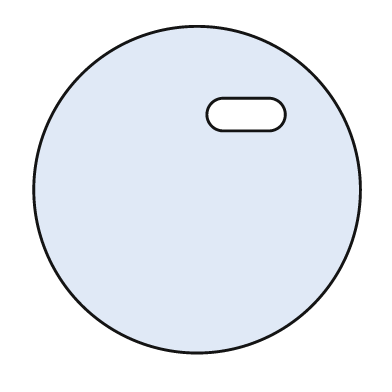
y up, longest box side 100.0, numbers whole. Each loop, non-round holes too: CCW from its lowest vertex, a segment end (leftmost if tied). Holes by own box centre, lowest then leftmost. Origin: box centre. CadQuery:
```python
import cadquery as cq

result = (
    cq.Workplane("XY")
    .moveTo(0.0, 0.0)
    .circle(50.0)
    .moveTo(8.0, 18.0)
    .lineTo(22.0, 18.0)
    .threePointArc((27.0, 23.0), (22.0, 28.0))
    .lineTo(8.0, 28.0)
    .threePointArc((3.0, 23.0), (8.0, 18.0))
    .close()
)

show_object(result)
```